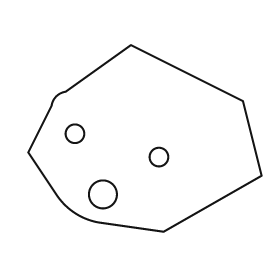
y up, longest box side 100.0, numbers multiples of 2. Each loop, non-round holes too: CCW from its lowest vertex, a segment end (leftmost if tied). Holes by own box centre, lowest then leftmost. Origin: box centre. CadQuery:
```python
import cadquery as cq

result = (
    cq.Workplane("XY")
    .moveTo(8.0, -40.0)
    .lineTo(50.0, -16.0)
    .lineTo(42.0, 16.0)
    .lineTo(-6.0, 40.0)
    .lineTo(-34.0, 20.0)
    .threePointArc((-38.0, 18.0), (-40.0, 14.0))
    .lineTo(-50.0, -6.0)
    .lineTo(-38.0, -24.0)
    .threePointArc((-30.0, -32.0), (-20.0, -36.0))
    .close()
    .moveTo(-18.0, -24.0)
    .circle(6.0)
    .moveTo(6.0, -8.0)
    .circle(4.0)
    .moveTo(-30.0, 2.0)
    .circle(4.0)
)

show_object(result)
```